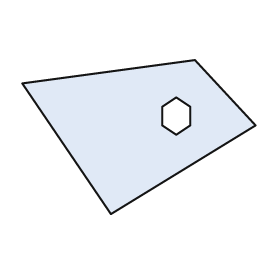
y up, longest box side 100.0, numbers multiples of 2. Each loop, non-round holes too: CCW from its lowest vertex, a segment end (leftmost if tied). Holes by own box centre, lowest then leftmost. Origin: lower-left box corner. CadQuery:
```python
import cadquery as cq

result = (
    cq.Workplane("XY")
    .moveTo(38.0, 0.0)
    .lineTo(100.0, 38.0)
    .lineTo(74.0, 66.0)
    .lineTo(0.0, 56.0)
    .close()
    .moveTo(66.0, 34.0)
    .lineTo(72.0, 38.0)
    .lineTo(72.0, 46.0)
    .lineTo(66.0, 50.0)
    .lineTo(60.0, 46.0)
    .lineTo(60.0, 38.0)
    .close()
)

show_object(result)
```